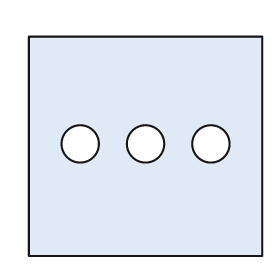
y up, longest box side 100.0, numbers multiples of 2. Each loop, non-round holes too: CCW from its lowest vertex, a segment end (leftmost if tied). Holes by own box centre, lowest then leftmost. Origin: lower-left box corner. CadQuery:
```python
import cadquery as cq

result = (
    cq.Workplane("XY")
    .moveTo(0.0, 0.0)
    .lineTo(100.0, 0.0)
    .lineTo(100.0, 94.0)
    .lineTo(0.0, 94.0)
    .close()
    .moveTo(22.0, 48.0)
    .circle(8.0)
    .moveTo(50.0, 48.0)
    .circle(8.0)
    .moveTo(78.0, 48.0)
    .circle(8.0)
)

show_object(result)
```